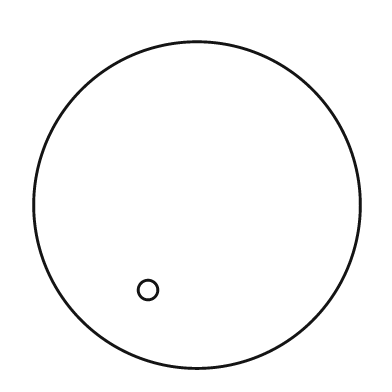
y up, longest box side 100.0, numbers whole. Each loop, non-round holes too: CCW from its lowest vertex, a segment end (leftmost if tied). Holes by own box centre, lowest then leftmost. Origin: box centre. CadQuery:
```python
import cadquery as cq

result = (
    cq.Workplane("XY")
    .moveTo(0.0, 0.0)
    .circle(50.0)
    .moveTo(-15.0, -26.0)
    .circle(3.0)
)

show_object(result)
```